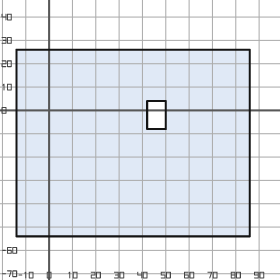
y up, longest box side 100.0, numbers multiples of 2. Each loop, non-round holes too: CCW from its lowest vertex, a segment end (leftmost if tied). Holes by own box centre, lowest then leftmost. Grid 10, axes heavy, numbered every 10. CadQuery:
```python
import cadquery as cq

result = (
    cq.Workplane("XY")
    .moveTo(-14.0, -54.0)
    .lineTo(86.0, -54.0)
    .lineTo(86.0, 26.0)
    .lineTo(-14.0, 26.0)
    .close()
    .moveTo(42.0, -8.0)
    .lineTo(50.0, -8.0)
    .lineTo(50.0, 4.0)
    .lineTo(42.0, 4.0)
    .close()
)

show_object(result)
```